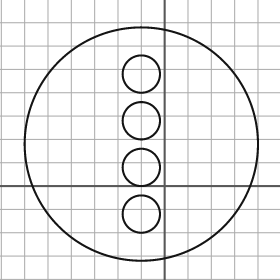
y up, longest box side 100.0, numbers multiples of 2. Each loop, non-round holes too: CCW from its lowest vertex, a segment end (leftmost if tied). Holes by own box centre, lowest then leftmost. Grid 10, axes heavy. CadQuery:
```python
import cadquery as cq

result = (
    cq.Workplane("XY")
    .moveTo(-10.0, 18.0)
    .circle(50.0)
    .moveTo(-10.0, -12.0)
    .circle(8.0)
    .moveTo(-10.0, 8.0)
    .circle(8.0)
    .moveTo(-10.0, 28.0)
    .circle(8.0)
    .moveTo(-10.0, 48.0)
    .circle(8.0)
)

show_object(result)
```